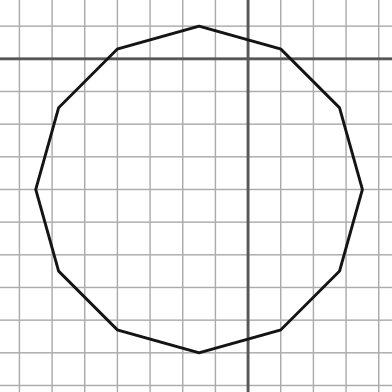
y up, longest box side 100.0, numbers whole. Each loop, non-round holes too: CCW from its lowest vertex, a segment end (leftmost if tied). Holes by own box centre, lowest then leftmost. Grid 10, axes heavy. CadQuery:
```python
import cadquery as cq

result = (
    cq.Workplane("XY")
    .moveTo(-15.0, -90.0)
    .lineTo(10.0, -83.0)
    .lineTo(28.0, -65.0)
    .lineTo(35.0, -40.0)
    .lineTo(28.0, -15.0)
    .lineTo(10.0, 3.0)
    .lineTo(-15.0, 10.0)
    .lineTo(-40.0, 3.0)
    .lineTo(-58.0, -15.0)
    .lineTo(-65.0, -40.0)
    .lineTo(-58.0, -65.0)
    .lineTo(-40.0, -83.0)
    .close()
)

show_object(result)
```